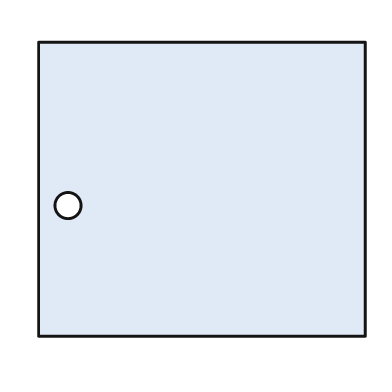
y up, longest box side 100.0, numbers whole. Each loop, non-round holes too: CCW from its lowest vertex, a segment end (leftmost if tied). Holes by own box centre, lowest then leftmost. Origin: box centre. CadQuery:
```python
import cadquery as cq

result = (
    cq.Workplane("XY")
    .moveTo(-50.0, -45.0)
    .lineTo(50.0, -45.0)
    .lineTo(50.0, 45.0)
    .lineTo(-50.0, 45.0)
    .close()
    .moveTo(-41.0, -5.0)
    .circle(4.0)
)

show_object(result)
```